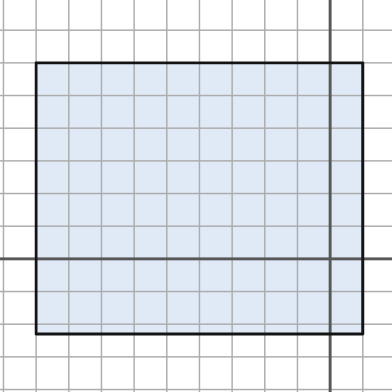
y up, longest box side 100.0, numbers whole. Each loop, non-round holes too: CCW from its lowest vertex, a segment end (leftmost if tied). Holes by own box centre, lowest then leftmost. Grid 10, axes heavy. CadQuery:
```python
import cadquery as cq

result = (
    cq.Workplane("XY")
    .moveTo(-90.0, -23.0)
    .lineTo(10.0, -23.0)
    .lineTo(10.0, 60.0)
    .lineTo(-90.0, 60.0)
    .close()
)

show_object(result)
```